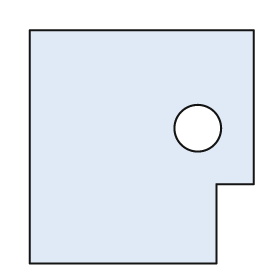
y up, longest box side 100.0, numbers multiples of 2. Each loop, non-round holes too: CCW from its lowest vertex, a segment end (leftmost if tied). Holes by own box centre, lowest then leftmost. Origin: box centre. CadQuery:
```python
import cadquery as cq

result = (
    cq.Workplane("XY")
    .moveTo(-48.0, -50.0)
    .lineTo(32.0, -50.0)
    .lineTo(32.0, -16.0)
    .lineTo(48.0, -16.0)
    .lineTo(48.0, 50.0)
    .lineTo(-48.0, 50.0)
    .close()
    .moveTo(24.0, 8.0)
    .circle(10.0)
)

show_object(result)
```